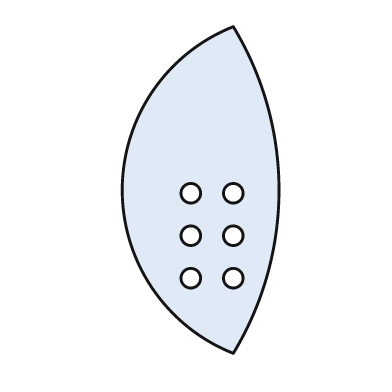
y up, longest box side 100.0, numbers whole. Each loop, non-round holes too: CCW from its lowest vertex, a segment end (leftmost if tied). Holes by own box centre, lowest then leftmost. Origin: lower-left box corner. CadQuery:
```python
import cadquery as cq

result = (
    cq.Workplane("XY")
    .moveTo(34.0, 0.0)
    .threePointArc((48.0, 50.0), (34.0, 100.0))
    .threePointArc((0.0, 50.0), (34.0, 0.0))
    .close()
    .moveTo(21.0, 23.0)
    .circle(3.0)
    .moveTo(34.0, 23.0)
    .circle(3.0)
    .moveTo(21.0, 36.0)
    .circle(3.0)
    .moveTo(34.0, 36.0)
    .circle(3.0)
    .moveTo(21.0, 49.0)
    .circle(3.0)
    .moveTo(34.0, 49.0)
    .circle(3.0)
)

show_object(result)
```